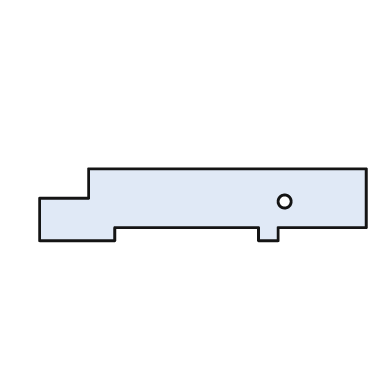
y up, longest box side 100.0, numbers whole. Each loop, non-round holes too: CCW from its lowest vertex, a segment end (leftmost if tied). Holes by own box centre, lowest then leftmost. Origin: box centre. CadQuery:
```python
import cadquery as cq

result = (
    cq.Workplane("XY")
    .moveTo(-50.0, -11.0)
    .lineTo(-27.0, -11.0)
    .lineTo(-27.0, -7.0)
    .lineTo(17.0, -7.0)
    .lineTo(17.0, -11.0)
    .lineTo(23.0, -11.0)
    .lineTo(23.0, -7.0)
    .lineTo(50.0, -7.0)
    .lineTo(50.0, 11.0)
    .lineTo(-35.0, 11.0)
    .lineTo(-35.0, 2.0)
    .lineTo(-50.0, 2.0)
    .close()
    .moveTo(25.0, 1.0)
    .circle(2.0)
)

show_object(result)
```